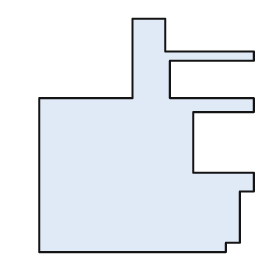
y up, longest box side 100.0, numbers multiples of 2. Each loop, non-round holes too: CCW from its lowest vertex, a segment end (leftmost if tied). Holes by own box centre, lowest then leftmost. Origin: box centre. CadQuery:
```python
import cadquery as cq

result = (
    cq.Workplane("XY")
    .moveTo(-46.0, -50.0)
    .lineTo(34.0, -50.0)
    .lineTo(34.0, -46.0)
    .lineTo(40.0, -46.0)
    .lineTo(40.0, -24.0)
    .lineTo(46.0, -24.0)
    .lineTo(46.0, -16.0)
    .lineTo(20.0, -16.0)
    .lineTo(20.0, 10.0)
    .lineTo(46.0, 10.0)
    .lineTo(46.0, 16.0)
    .lineTo(10.0, 16.0)
    .lineTo(10.0, 32.0)
    .lineTo(46.0, 32.0)
    .lineTo(46.0, 36.0)
    .lineTo(8.0, 36.0)
    .lineTo(8.0, 50.0)
    .lineTo(-6.0, 50.0)
    .lineTo(-6.0, 16.0)
    .lineTo(-46.0, 16.0)
    .close()
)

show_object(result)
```